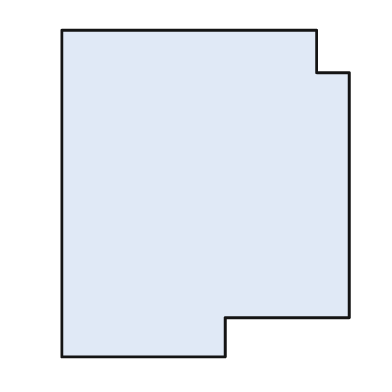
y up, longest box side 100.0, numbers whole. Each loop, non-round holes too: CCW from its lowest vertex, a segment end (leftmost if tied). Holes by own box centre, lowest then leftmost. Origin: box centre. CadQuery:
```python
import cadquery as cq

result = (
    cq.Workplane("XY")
    .moveTo(-44.0, -50.0)
    .lineTo(6.0, -50.0)
    .lineTo(6.0, -38.0)
    .lineTo(44.0, -38.0)
    .lineTo(44.0, 37.0)
    .lineTo(34.0, 37.0)
    .lineTo(34.0, 50.0)
    .lineTo(-44.0, 50.0)
    .close()
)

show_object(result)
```